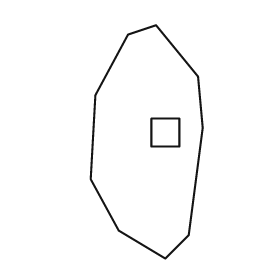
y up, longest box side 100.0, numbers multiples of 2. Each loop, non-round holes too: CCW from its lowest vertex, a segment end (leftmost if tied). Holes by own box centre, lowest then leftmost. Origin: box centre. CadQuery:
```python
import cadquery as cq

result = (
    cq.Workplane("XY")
    .moveTo(8.0, -50.0)
    .lineTo(18.0, -40.0)
    .lineTo(24.0, 6.0)
    .lineTo(22.0, 28.0)
    .lineTo(4.0, 50.0)
    .lineTo(-8.0, 46.0)
    .lineTo(-22.0, 20.0)
    .lineTo(-24.0, -16.0)
    .lineTo(-12.0, -38.0)
    .close()
    .moveTo(2.0, -2.0)
    .lineTo(14.0, -2.0)
    .lineTo(14.0, 10.0)
    .lineTo(2.0, 10.0)
    .close()
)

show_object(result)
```